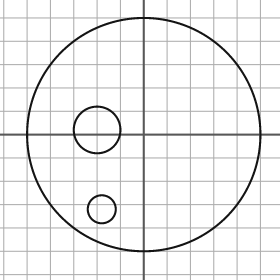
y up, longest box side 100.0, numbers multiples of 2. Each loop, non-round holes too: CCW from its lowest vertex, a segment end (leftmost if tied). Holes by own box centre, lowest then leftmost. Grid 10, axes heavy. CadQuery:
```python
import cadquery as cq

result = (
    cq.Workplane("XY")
    .moveTo(0.0, 0.0)
    .circle(50.0)
    .moveTo(-18.0, -32.0)
    .circle(6.0)
    .moveTo(-20.0, 2.0)
    .circle(10.0)
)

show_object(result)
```